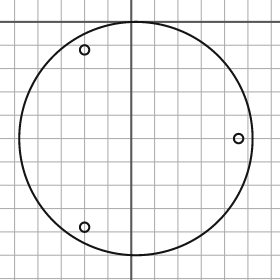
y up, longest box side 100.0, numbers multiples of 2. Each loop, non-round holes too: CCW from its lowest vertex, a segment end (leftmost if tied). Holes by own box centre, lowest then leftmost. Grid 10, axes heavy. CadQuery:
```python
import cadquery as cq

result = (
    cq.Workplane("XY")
    .moveTo(2.0, -50.0)
    .circle(50.0)
    .moveTo(-20.0, -88.0)
    .circle(2.0)
    .moveTo(46.0, -50.0)
    .circle(2.0)
    .moveTo(-20.0, -12.0)
    .circle(2.0)
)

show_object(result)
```